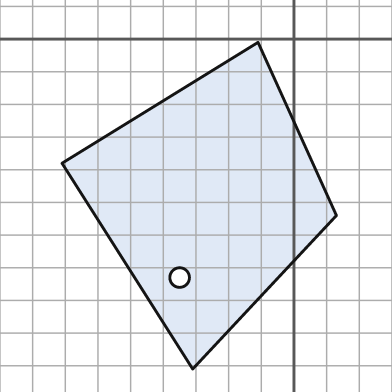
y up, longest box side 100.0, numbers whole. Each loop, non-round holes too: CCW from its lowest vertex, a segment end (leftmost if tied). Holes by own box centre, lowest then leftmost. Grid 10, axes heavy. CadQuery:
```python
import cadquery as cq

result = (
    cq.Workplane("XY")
    .moveTo(-31.0, -101.0)
    .lineTo(13.0, -54.0)
    .lineTo(-11.0, -1.0)
    .lineTo(-71.0, -38.0)
    .close()
    .moveTo(-35.0, -73.0)
    .circle(3.0)
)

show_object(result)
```